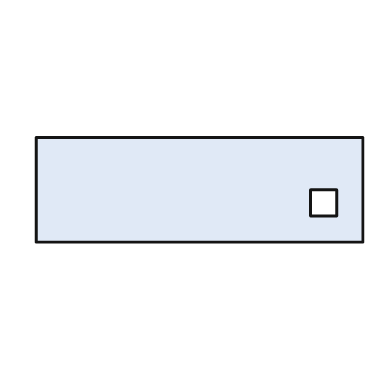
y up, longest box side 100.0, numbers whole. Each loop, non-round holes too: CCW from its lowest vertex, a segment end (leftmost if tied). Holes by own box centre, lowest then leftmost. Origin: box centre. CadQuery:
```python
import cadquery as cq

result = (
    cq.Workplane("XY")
    .moveTo(-50.0, -16.0)
    .lineTo(50.0, -16.0)
    .lineTo(50.0, 16.0)
    .lineTo(-50.0, 16.0)
    .close()
    .moveTo(34.0, -8.0)
    .lineTo(42.0, -8.0)
    .lineTo(42.0, 0.0)
    .lineTo(34.0, 0.0)
    .close()
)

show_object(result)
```